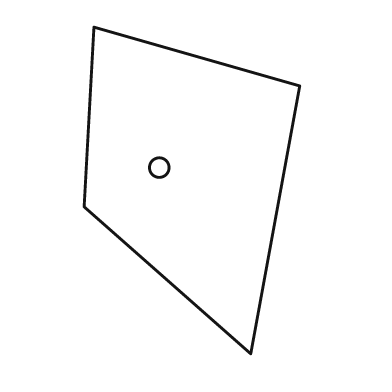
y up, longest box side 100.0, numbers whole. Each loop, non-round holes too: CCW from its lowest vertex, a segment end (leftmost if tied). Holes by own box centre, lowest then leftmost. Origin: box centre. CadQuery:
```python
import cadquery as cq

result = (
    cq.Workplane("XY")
    .moveTo(18.0, -50.0)
    .lineTo(33.0, 32.0)
    .lineTo(-30.0, 50.0)
    .lineTo(-33.0, -5.0)
    .close()
    .moveTo(-10.0, 7.0)
    .circle(3.0)
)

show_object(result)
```